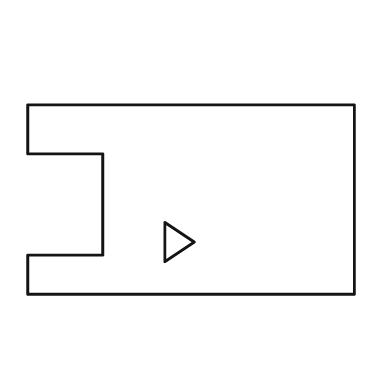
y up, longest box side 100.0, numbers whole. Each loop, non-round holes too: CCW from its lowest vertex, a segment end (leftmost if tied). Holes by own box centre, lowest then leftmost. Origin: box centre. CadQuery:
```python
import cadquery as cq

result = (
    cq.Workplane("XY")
    .moveTo(-50.0, -29.0)
    .lineTo(50.0, -29.0)
    .lineTo(50.0, 29.0)
    .lineTo(-50.0, 29.0)
    .lineTo(-50.0, 14.0)
    .lineTo(-27.0, 14.0)
    .lineTo(-27.0, -17.0)
    .lineTo(-50.0, -17.0)
    .close()
    .moveTo(-8.0, -19.0)
    .lineTo(1.0, -13.0)
    .lineTo(-8.0, -7.0)
    .close()
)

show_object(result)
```